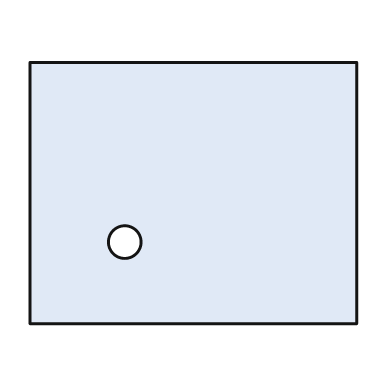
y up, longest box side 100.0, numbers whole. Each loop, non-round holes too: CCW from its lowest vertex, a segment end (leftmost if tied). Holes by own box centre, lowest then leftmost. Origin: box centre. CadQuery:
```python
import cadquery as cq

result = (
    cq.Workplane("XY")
    .moveTo(-50.0, -40.0)
    .lineTo(50.0, -40.0)
    .lineTo(50.0, 40.0)
    .lineTo(-50.0, 40.0)
    .close()
    .moveTo(-21.0, -15.0)
    .circle(5.0)
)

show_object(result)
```